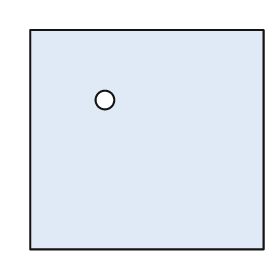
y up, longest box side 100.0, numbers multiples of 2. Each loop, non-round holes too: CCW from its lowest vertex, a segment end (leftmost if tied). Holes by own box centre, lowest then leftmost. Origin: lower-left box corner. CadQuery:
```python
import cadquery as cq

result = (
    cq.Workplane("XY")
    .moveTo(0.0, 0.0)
    .lineTo(100.0, 0.0)
    .lineTo(100.0, 94.0)
    .lineTo(0.0, 94.0)
    .close()
    .moveTo(32.0, 64.0)
    .circle(4.0)
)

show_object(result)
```